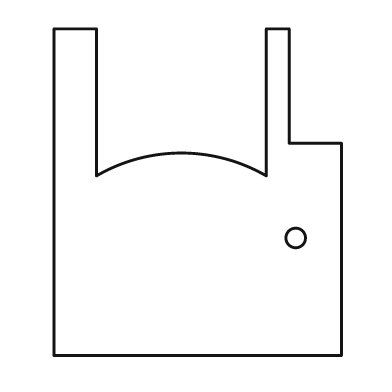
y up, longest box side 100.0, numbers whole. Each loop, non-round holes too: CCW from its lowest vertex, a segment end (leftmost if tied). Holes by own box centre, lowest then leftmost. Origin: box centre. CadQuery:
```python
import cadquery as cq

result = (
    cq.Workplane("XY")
    .moveTo(-44.0, -50.0)
    .lineTo(44.0, -50.0)
    .lineTo(44.0, 15.0)
    .lineTo(28.0, 15.0)
    .lineTo(28.0, 50.0)
    .lineTo(21.0, 50.0)
    .lineTo(21.0, 5.0)
    .threePointArc((-5.0, 12.0), (-31.0, 5.0))
    .lineTo(-31.0, 50.0)
    .lineTo(-44.0, 50.0)
    .close()
    .moveTo(30.0, -14.0)
    .circle(3.0)
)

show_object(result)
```